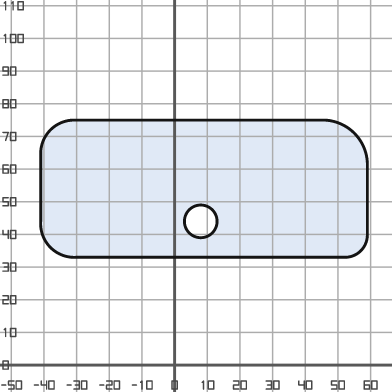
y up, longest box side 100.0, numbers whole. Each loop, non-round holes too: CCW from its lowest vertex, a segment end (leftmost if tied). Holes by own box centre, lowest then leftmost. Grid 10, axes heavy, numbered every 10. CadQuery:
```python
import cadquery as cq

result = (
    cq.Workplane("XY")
    .moveTo(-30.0, 33.0)
    .lineTo(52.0, 33.0)
    .threePointArc((57.0, 35.0), (59.0, 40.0))
    .lineTo(59.0, 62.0)
    .threePointArc((55.0, 71.0), (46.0, 75.0))
    .lineTo(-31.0, 75.0)
    .threePointArc((-38.0, 72.0), (-41.0, 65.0))
    .lineTo(-41.0, 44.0)
    .threePointArc((-38.0, 36.0), (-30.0, 33.0))
    .close()
    .moveTo(8.0, 44.0)
    .circle(5.0)
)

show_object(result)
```